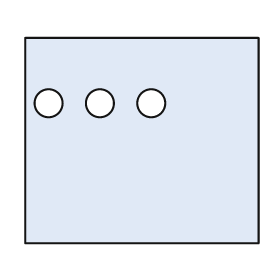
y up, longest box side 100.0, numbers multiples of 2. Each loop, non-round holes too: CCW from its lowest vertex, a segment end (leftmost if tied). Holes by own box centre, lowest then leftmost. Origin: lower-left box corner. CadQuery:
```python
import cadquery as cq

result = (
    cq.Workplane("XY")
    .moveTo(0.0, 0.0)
    .lineTo(100.0, 0.0)
    .lineTo(100.0, 88.0)
    .lineTo(0.0, 88.0)
    .close()
    .moveTo(10.0, 60.0)
    .circle(6.0)
    .moveTo(32.0, 60.0)
    .circle(6.0)
    .moveTo(54.0, 60.0)
    .circle(6.0)
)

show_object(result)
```